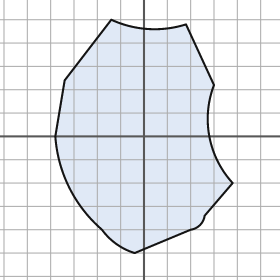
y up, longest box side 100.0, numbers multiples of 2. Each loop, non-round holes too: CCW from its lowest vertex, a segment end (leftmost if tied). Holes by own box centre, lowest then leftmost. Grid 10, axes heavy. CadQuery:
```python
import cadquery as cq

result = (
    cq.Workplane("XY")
    .moveTo(-4.0, -50.0)
    .lineTo(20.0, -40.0)
    .threePointArc((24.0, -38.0), (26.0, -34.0))
    .lineTo(38.0, -20.0)
    .threePointArc((28.0, 0.0), (30.0, 22.0))
    .lineTo(18.0, 48.0)
    .threePointArc((2.0, 46.0), (-14.0, 50.0))
    .lineTo(-34.0, 24.0)
    .lineTo(-38.0, 0.0)
    .threePointArc((-32.0, -22.0), (-18.0, -40.0))
    .threePointArc((-12.0, -46.0), (-4.0, -50.0))
    .close()
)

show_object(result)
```